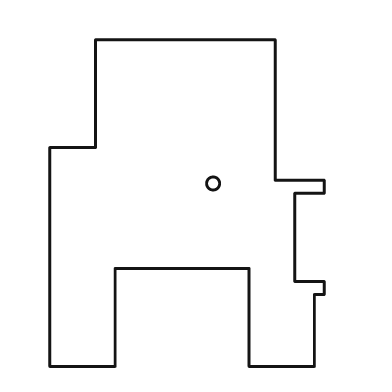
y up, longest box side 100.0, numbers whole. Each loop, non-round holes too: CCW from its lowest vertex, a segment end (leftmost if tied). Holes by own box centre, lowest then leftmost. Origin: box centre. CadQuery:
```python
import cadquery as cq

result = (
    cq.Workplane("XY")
    .moveTo(-42.0, -50.0)
    .lineTo(-22.0, -50.0)
    .lineTo(-22.0, -20.0)
    .lineTo(19.0, -20.0)
    .lineTo(19.0, -50.0)
    .lineTo(39.0, -50.0)
    .lineTo(39.0, -28.0)
    .lineTo(42.0, -28.0)
    .lineTo(42.0, -24.0)
    .lineTo(33.0, -24.0)
    .lineTo(33.0, 3.0)
    .lineTo(42.0, 3.0)
    .lineTo(42.0, 7.0)
    .lineTo(27.0, 7.0)
    .lineTo(27.0, 50.0)
    .lineTo(-28.0, 50.0)
    .lineTo(-28.0, 17.0)
    .lineTo(-42.0, 17.0)
    .close()
    .moveTo(8.0, 6.0)
    .circle(2.0)
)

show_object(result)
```